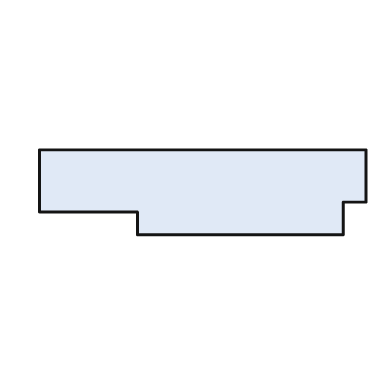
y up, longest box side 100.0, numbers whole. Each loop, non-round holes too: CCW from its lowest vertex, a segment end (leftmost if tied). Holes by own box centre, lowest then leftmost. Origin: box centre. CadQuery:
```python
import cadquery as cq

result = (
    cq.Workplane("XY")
    .moveTo(-20.0, -13.0)
    .lineTo(43.0, -13.0)
    .lineTo(43.0, -3.0)
    .lineTo(50.0, -3.0)
    .lineTo(50.0, 13.0)
    .lineTo(-50.0, 13.0)
    .lineTo(-50.0, -6.0)
    .lineTo(-20.0, -6.0)
    .close()
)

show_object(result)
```